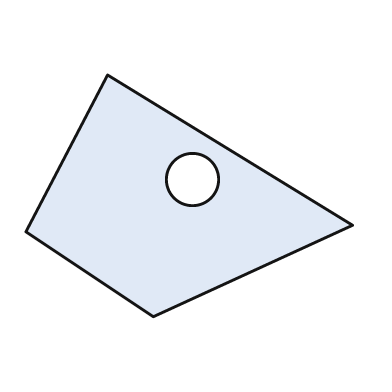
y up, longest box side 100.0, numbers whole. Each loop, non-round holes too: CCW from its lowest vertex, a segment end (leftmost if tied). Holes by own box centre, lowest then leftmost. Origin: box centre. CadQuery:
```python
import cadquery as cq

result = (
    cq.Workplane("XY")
    .moveTo(-11.0, -37.0)
    .lineTo(50.0, -9.0)
    .lineTo(-25.0, 37.0)
    .lineTo(-50.0, -11.0)
    .close()
    .moveTo(1.0, 5.0)
    .circle(8.0)
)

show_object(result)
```